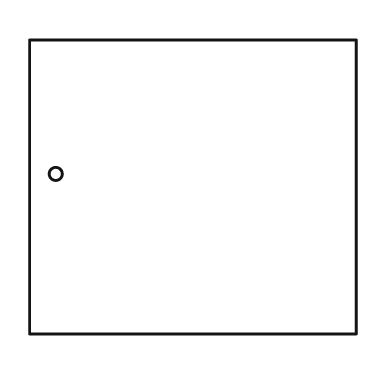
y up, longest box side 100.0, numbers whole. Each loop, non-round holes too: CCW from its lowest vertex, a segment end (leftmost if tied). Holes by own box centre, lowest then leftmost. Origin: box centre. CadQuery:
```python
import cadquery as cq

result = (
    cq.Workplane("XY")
    .moveTo(-50.0, -45.0)
    .lineTo(50.0, -45.0)
    .lineTo(50.0, 45.0)
    .lineTo(-50.0, 45.0)
    .close()
    .moveTo(-42.0, 4.0)
    .circle(2.0)
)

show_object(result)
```